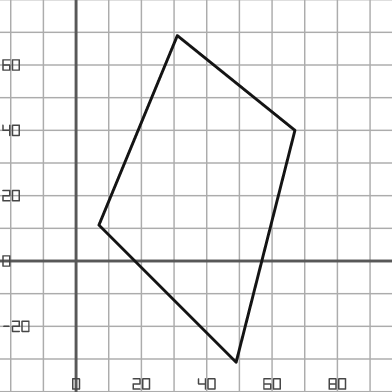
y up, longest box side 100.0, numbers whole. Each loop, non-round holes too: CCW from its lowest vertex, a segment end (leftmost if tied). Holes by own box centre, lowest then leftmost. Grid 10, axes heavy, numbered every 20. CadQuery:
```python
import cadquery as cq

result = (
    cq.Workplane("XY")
    .moveTo(49.0, -31.0)
    .lineTo(67.0, 40.0)
    .lineTo(31.0, 69.0)
    .lineTo(7.0, 11.0)
    .close()
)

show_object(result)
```